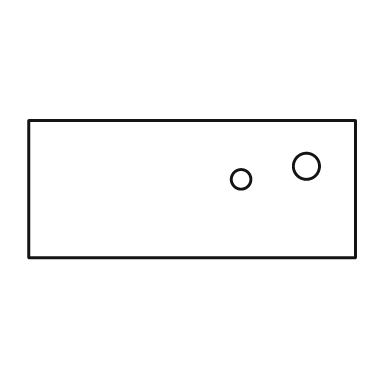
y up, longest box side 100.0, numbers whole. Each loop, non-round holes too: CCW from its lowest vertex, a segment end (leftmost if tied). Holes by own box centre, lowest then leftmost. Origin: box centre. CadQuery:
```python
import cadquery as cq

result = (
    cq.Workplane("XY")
    .moveTo(-50.0, -21.0)
    .lineTo(50.0, -21.0)
    .lineTo(50.0, 21.0)
    .lineTo(-50.0, 21.0)
    .close()
    .moveTo(15.0, 3.0)
    .circle(3.0)
    .moveTo(35.0, 7.0)
    .circle(4.0)
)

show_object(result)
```